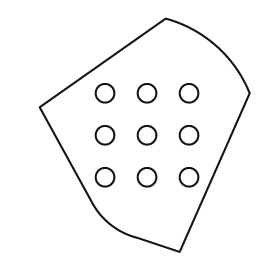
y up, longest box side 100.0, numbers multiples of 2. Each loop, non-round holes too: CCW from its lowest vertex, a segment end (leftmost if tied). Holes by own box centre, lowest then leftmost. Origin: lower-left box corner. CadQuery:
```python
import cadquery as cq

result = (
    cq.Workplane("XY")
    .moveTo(60.0, 0.0)
    .lineTo(90.0, 68.0)
    .threePointArc((76.0, 88.0), (54.0, 100.0))
    .lineTo(0.0, 62.0)
    .lineTo(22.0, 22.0)
    .threePointArc((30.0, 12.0), (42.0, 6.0))
    .close()
    .moveTo(28.0, 32.0)
    .circle(4.0)
    .moveTo(46.0, 32.0)
    .circle(4.0)
    .moveTo(64.0, 32.0)
    .circle(4.0)
    .moveTo(28.0, 50.0)
    .circle(4.0)
    .moveTo(46.0, 50.0)
    .circle(4.0)
    .moveTo(64.0, 50.0)
    .circle(4.0)
    .moveTo(28.0, 68.0)
    .circle(4.0)
    .moveTo(46.0, 68.0)
    .circle(4.0)
    .moveTo(64.0, 68.0)
    .circle(4.0)
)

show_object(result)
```